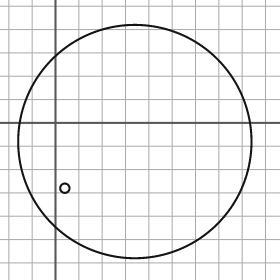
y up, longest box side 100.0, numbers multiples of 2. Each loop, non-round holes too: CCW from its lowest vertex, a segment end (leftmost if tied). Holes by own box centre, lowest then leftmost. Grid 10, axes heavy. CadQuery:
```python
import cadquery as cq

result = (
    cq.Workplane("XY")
    .moveTo(34.0, -8.0)
    .circle(50.0)
    .moveTo(4.0, -28.0)
    .circle(2.0)
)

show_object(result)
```